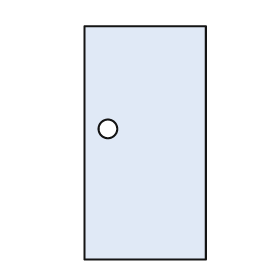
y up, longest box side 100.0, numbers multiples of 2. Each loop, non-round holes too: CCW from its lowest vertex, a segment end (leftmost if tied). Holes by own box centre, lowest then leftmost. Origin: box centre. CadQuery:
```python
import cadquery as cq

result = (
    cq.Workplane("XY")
    .moveTo(-26.0, -50.0)
    .lineTo(26.0, -50.0)
    .lineTo(26.0, 50.0)
    .lineTo(-26.0, 50.0)
    .close()
    .moveTo(-16.0, 6.0)
    .circle(4.0)
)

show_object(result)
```